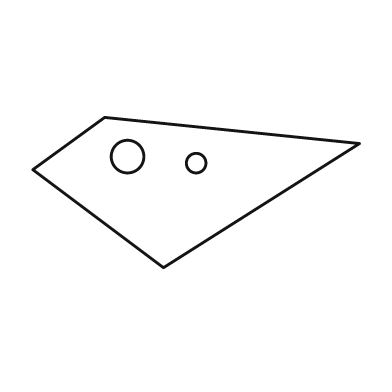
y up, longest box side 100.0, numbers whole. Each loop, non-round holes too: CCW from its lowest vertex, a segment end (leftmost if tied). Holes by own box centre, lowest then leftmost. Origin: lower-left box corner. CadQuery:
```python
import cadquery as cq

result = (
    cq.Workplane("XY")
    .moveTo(40.0, 0.0)
    .lineTo(100.0, 38.0)
    .lineTo(22.0, 46.0)
    .lineTo(0.0, 30.0)
    .close()
    .moveTo(50.0, 32.0)
    .circle(3.0)
    .moveTo(29.0, 34.0)
    .circle(5.0)
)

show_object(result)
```